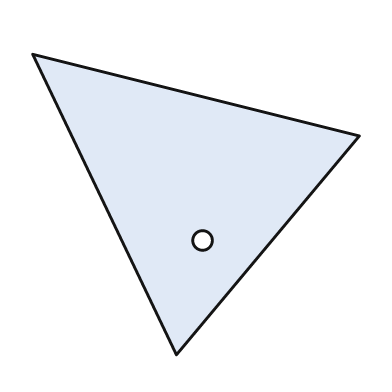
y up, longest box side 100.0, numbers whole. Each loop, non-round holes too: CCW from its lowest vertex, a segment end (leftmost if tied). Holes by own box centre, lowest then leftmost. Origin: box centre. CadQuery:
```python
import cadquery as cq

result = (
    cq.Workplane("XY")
    .moveTo(-6.0, -46.0)
    .lineTo(50.0, 21.0)
    .lineTo(-50.0, 46.0)
    .close()
    .moveTo(2.0, -11.0)
    .circle(3.0)
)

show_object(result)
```